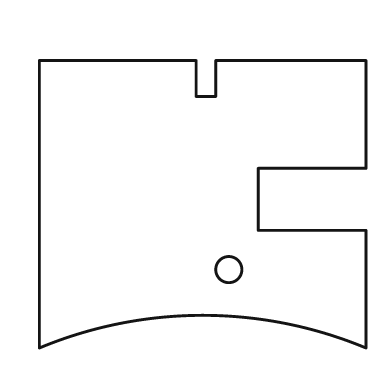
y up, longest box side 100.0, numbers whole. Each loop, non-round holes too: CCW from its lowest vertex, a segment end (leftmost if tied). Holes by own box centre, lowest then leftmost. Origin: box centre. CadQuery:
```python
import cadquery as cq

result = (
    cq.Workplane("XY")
    .moveTo(-50.0, -44.0)
    .threePointArc((0.0, -34.0), (50.0, -44.0))
    .lineTo(50.0, -8.0)
    .lineTo(17.0, -8.0)
    .lineTo(17.0, 11.0)
    .lineTo(50.0, 11.0)
    .lineTo(50.0, 44.0)
    .lineTo(4.0, 44.0)
    .lineTo(4.0, 33.0)
    .lineTo(-2.0, 33.0)
    .lineTo(-2.0, 44.0)
    .lineTo(-50.0, 44.0)
    .close()
    .moveTo(8.0, -20.0)
    .circle(4.0)
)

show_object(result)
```